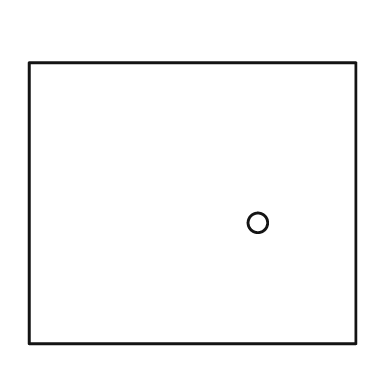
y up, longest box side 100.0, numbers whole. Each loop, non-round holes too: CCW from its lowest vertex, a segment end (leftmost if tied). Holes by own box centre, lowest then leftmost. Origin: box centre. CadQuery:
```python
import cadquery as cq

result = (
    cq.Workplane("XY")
    .moveTo(-50.0, -43.0)
    .lineTo(50.0, -43.0)
    .lineTo(50.0, 43.0)
    .lineTo(-50.0, 43.0)
    .close()
    .moveTo(20.0, -6.0)
    .circle(3.0)
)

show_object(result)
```